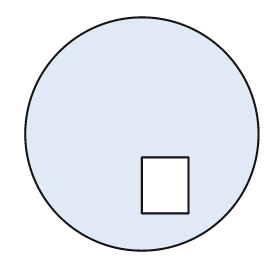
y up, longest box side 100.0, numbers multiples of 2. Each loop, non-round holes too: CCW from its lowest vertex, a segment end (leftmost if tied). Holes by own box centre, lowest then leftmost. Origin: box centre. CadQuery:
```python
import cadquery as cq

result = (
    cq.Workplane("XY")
    .moveTo(0.0, 0.0)
    .circle(50.0)
    .moveTo(0.0, -34.0)
    .lineTo(20.0, -34.0)
    .lineTo(20.0, -10.0)
    .lineTo(0.0, -10.0)
    .close()
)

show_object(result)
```